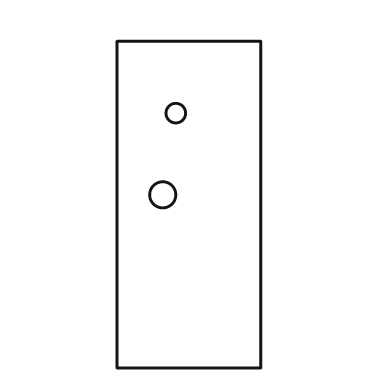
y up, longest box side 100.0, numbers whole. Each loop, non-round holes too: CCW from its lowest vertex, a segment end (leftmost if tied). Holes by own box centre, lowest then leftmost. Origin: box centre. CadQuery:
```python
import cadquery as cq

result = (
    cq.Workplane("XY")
    .moveTo(-22.0, -50.0)
    .lineTo(22.0, -50.0)
    .lineTo(22.0, 50.0)
    .lineTo(-22.0, 50.0)
    .close()
    .moveTo(-8.0, 3.0)
    .circle(4.0)
    .moveTo(-4.0, 28.0)
    .circle(3.0)
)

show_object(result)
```